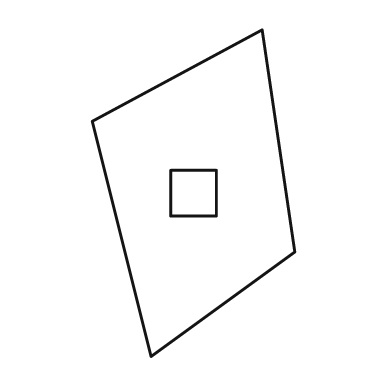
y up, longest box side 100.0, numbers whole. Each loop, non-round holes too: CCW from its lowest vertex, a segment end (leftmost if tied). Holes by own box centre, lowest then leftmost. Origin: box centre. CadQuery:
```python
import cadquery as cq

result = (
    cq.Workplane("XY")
    .moveTo(-13.0, -50.0)
    .lineTo(31.0, -18.0)
    .lineTo(21.0, 50.0)
    .lineTo(-31.0, 22.0)
    .close()
    .moveTo(-7.0, -7.0)
    .lineTo(7.0, -7.0)
    .lineTo(7.0, 7.0)
    .lineTo(-7.0, 7.0)
    .close()
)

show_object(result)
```